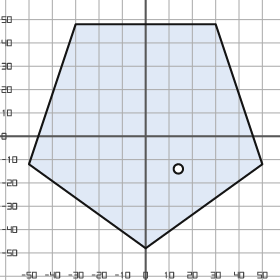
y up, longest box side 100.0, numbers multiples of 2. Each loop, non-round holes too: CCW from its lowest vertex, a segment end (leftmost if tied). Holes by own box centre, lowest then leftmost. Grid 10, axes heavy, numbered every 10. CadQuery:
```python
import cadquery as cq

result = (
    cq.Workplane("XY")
    .moveTo(0.0, -48.0)
    .lineTo(50.0, -12.0)
    .lineTo(30.0, 48.0)
    .lineTo(-30.0, 48.0)
    .lineTo(-50.0, -12.0)
    .close()
    .moveTo(14.0, -14.0)
    .circle(2.0)
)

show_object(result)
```